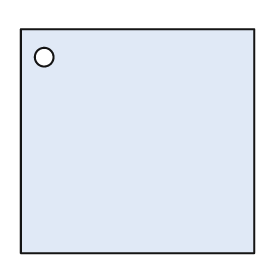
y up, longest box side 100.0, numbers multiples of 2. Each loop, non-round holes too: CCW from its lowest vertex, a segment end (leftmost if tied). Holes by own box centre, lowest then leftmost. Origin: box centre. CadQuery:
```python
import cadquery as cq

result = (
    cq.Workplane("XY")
    .moveTo(-50.0, -48.0)
    .lineTo(50.0, -48.0)
    .lineTo(50.0, 48.0)
    .lineTo(-50.0, 48.0)
    .close()
    .moveTo(-40.0, 36.0)
    .circle(4.0)
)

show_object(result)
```